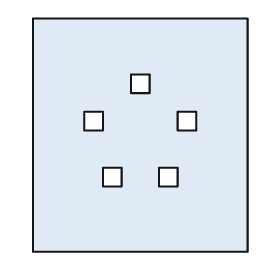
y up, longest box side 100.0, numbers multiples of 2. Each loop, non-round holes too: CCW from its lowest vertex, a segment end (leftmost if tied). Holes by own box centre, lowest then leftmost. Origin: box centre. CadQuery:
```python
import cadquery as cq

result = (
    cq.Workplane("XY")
    .moveTo(-46.0, -50.0)
    .lineTo(46.0, -50.0)
    .lineTo(46.0, 50.0)
    .lineTo(-46.0, 50.0)
    .close()
    .moveTo(-16.0, -22.0)
    .lineTo(-8.0, -22.0)
    .lineTo(-8.0, -14.0)
    .lineTo(-16.0, -14.0)
    .close()
    .moveTo(8.0, -22.0)
    .lineTo(16.0, -22.0)
    .lineTo(16.0, -14.0)
    .lineTo(8.0, -14.0)
    .close()
    .moveTo(-24.0, 2.0)
    .lineTo(-16.0, 2.0)
    .lineTo(-16.0, 10.0)
    .lineTo(-24.0, 10.0)
    .close()
    .moveTo(16.0, 2.0)
    .lineTo(24.0, 2.0)
    .lineTo(24.0, 10.0)
    .lineTo(16.0, 10.0)
    .close()
    .moveTo(-4.0, 18.0)
    .lineTo(4.0, 18.0)
    .lineTo(4.0, 26.0)
    .lineTo(-4.0, 26.0)
    .close()
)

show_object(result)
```